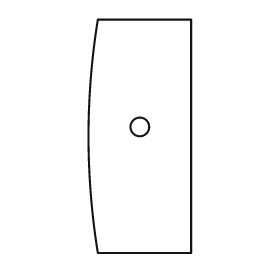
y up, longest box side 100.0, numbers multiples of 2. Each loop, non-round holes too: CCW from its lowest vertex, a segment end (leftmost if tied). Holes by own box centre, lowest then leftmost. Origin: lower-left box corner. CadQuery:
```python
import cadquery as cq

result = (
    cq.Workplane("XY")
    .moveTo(4.0, 0.0)
    .lineTo(44.0, 0.0)
    .lineTo(44.0, 100.0)
    .lineTo(4.0, 100.0)
    .threePointArc((0.0, 50.0), (4.0, 0.0))
    .close()
    .moveTo(22.0, 54.0)
    .circle(4.0)
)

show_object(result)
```